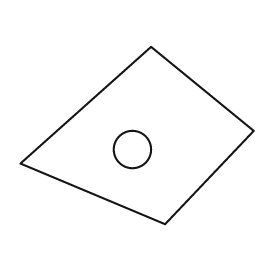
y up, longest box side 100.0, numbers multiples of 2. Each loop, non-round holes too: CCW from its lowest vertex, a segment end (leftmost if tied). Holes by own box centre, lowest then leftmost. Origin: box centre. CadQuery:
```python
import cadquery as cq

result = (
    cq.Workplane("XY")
    .moveTo(12.0, -38.0)
    .lineTo(50.0, 2.0)
    .lineTo(6.0, 38.0)
    .lineTo(-50.0, -12.0)
    .close()
    .moveTo(-2.0, -6.0)
    .circle(8.0)
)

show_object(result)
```